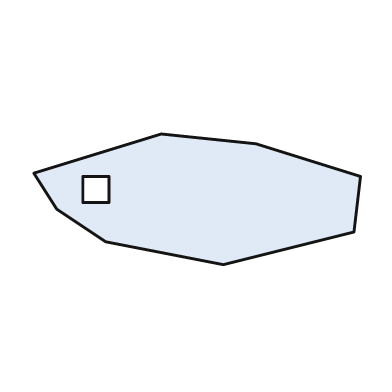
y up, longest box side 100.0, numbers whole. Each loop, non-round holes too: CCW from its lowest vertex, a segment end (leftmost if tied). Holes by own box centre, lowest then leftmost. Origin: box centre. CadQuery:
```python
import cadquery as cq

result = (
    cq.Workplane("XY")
    .moveTo(8.0, -20.0)
    .lineTo(48.0, -10.0)
    .lineTo(50.0, 7.0)
    .lineTo(18.0, 17.0)
    .lineTo(-11.0, 20.0)
    .lineTo(-50.0, 8.0)
    .lineTo(-43.0, -3.0)
    .lineTo(-28.0, -13.0)
    .close()
    .moveTo(-35.0, -1.0)
    .lineTo(-27.0, -1.0)
    .lineTo(-27.0, 7.0)
    .lineTo(-35.0, 7.0)
    .close()
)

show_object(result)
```